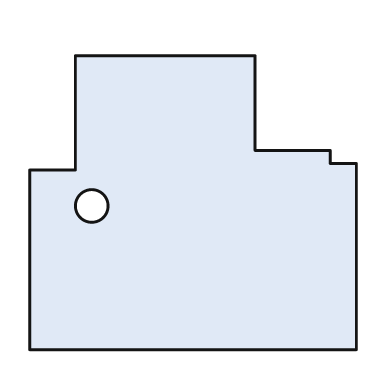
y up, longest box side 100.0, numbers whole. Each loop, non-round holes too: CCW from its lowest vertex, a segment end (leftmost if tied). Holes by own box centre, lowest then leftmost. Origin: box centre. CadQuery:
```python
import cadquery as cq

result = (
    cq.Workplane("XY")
    .moveTo(-50.0, -45.0)
    .lineTo(50.0, -45.0)
    .lineTo(50.0, 12.0)
    .lineTo(42.0, 12.0)
    .lineTo(42.0, 16.0)
    .lineTo(19.0, 16.0)
    .lineTo(19.0, 45.0)
    .lineTo(-36.0, 45.0)
    .lineTo(-36.0, 10.0)
    .lineTo(-50.0, 10.0)
    .close()
    .moveTo(-31.0, -1.0)
    .circle(5.0)
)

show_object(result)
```